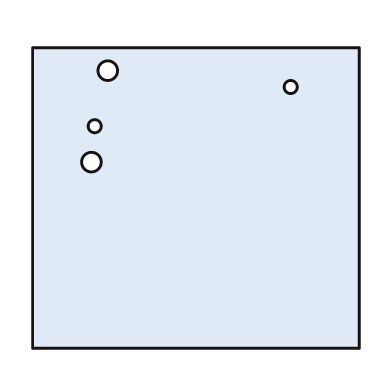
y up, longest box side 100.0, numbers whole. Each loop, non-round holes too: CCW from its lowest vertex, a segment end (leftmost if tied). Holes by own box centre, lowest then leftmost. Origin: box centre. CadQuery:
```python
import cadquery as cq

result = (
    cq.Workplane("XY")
    .moveTo(-50.0, -46.0)
    .lineTo(50.0, -46.0)
    .lineTo(50.0, 46.0)
    .lineTo(-50.0, 46.0)
    .close()
    .moveTo(-32.0, 11.0)
    .circle(3.0)
    .moveTo(-31.0, 22.0)
    .circle(2.0)
    .moveTo(29.0, 34.0)
    .circle(2.0)
    .moveTo(-27.0, 39.0)
    .circle(3.0)
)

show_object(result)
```